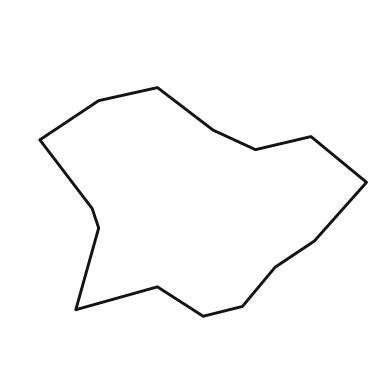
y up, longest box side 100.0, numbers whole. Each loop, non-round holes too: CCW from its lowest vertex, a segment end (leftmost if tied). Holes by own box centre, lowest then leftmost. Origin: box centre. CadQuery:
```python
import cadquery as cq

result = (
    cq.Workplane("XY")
    .moveTo(0.0, -35.0)
    .lineTo(12.0, -32.0)
    .lineTo(22.0, -20.0)
    .lineTo(34.0, -12.0)
    .lineTo(50.0, 6.0)
    .lineTo(33.0, 20.0)
    .lineTo(16.0, 16.0)
    .lineTo(3.0, 22.0)
    .lineTo(-14.0, 35.0)
    .lineTo(-32.0, 31.0)
    .lineTo(-50.0, 19.0)
    .lineTo(-34.0, -2.0)
    .lineTo(-32.0, -8.0)
    .lineTo(-39.0, -33.0)
    .lineTo(-14.0, -26.0)
    .close()
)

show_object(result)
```